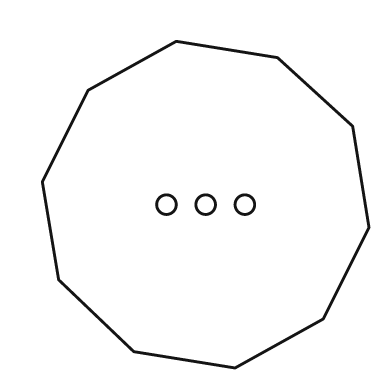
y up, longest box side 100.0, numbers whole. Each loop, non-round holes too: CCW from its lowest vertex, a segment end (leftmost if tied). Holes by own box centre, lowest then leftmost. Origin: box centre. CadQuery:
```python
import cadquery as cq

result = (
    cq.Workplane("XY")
    .moveTo(9.0, -50.0)
    .lineTo(36.0, -35.0)
    .lineTo(50.0, -7.0)
    .lineTo(45.0, 24.0)
    .lineTo(22.0, 45.0)
    .lineTo(-9.0, 50.0)
    .lineTo(-36.0, 35.0)
    .lineTo(-50.0, 7.0)
    .lineTo(-45.0, -23.0)
    .lineTo(-22.0, -45.0)
    .close()
    .moveTo(-12.0, 0.0)
    .circle(3.0)
    .moveTo(0.0, 0.0)
    .circle(3.0)
    .moveTo(12.0, 0.0)
    .circle(3.0)
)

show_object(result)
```